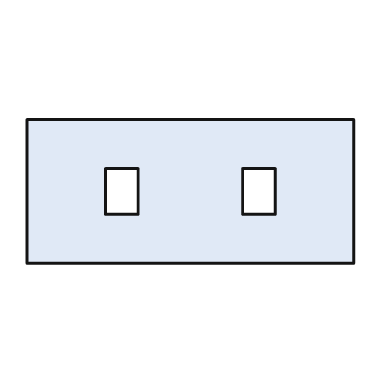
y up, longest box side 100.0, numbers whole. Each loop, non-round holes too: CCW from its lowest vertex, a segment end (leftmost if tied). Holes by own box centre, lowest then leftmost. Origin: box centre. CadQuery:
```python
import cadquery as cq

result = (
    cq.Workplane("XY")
    .moveTo(-50.0, -22.0)
    .lineTo(50.0, -22.0)
    .lineTo(50.0, 22.0)
    .lineTo(-50.0, 22.0)
    .close()
    .moveTo(-26.0, -7.0)
    .lineTo(-16.0, -7.0)
    .lineTo(-16.0, 7.0)
    .lineTo(-26.0, 7.0)
    .close()
    .moveTo(16.0, -7.0)
    .lineTo(26.0, -7.0)
    .lineTo(26.0, 7.0)
    .lineTo(16.0, 7.0)
    .close()
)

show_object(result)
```